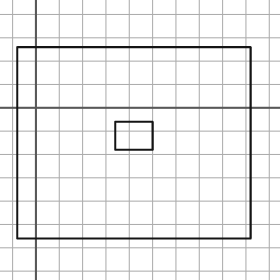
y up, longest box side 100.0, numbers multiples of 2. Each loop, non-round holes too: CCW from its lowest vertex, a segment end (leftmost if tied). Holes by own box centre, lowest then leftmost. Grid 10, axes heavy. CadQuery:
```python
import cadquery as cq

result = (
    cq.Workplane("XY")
    .moveTo(-8.0, -56.0)
    .lineTo(92.0, -56.0)
    .lineTo(92.0, 26.0)
    .lineTo(-8.0, 26.0)
    .close()
    .moveTo(34.0, -18.0)
    .lineTo(50.0, -18.0)
    .lineTo(50.0, -6.0)
    .lineTo(34.0, -6.0)
    .close()
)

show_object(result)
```